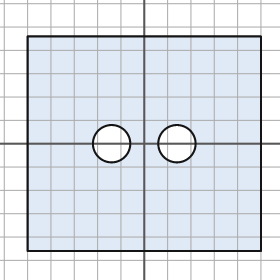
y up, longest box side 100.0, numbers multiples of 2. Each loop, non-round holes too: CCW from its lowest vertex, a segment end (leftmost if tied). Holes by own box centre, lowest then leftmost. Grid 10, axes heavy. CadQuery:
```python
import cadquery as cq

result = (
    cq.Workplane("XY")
    .moveTo(-50.0, -46.0)
    .lineTo(50.0, -46.0)
    .lineTo(50.0, 46.0)
    .lineTo(-50.0, 46.0)
    .close()
    .moveTo(-14.0, 0.0)
    .circle(8.0)
    .moveTo(14.0, 0.0)
    .circle(8.0)
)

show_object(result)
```